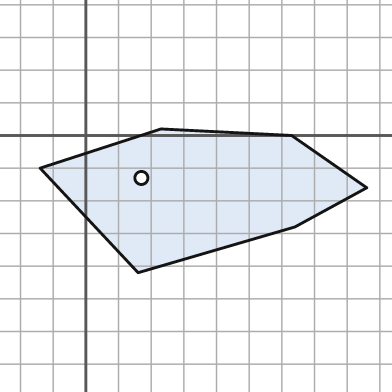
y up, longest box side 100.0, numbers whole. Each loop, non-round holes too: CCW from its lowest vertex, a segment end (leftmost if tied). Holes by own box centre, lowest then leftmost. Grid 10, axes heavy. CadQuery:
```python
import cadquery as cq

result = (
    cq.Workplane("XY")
    .moveTo(16.0, -42.0)
    .lineTo(64.0, -28.0)
    .lineTo(86.0, -16.0)
    .lineTo(63.0, 0.0)
    .lineTo(23.0, 2.0)
    .lineTo(-14.0, -10.0)
    .close()
    .moveTo(17.0, -13.0)
    .circle(2.0)
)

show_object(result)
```